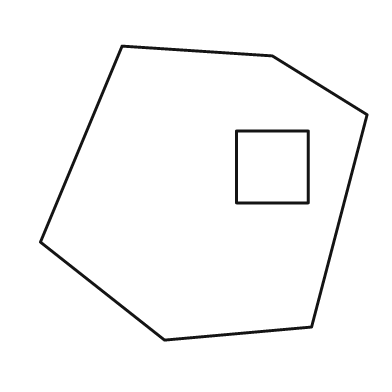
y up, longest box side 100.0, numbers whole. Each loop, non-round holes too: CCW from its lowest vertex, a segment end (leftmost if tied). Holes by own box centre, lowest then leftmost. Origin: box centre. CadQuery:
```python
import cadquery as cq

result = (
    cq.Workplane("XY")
    .moveTo(-12.0, -45.0)
    .lineTo(33.0, -41.0)
    .lineTo(50.0, 24.0)
    .lineTo(21.0, 42.0)
    .lineTo(-25.0, 45.0)
    .lineTo(-50.0, -15.0)
    .close()
    .moveTo(10.0, -3.0)
    .lineTo(32.0, -3.0)
    .lineTo(32.0, 19.0)
    .lineTo(10.0, 19.0)
    .close()
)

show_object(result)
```